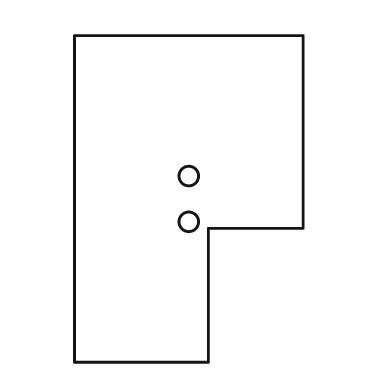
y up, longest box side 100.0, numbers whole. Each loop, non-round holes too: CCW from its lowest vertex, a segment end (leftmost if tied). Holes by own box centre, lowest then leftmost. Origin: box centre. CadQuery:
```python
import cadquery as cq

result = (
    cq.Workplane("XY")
    .moveTo(-35.0, -50.0)
    .lineTo(6.0, -50.0)
    .lineTo(6.0, -9.0)
    .lineTo(35.0, -9.0)
    .lineTo(35.0, 50.0)
    .lineTo(-35.0, 50.0)
    .close()
    .moveTo(0.0, -7.0)
    .circle(3.0)
    .moveTo(0.0, 7.0)
    .circle(3.0)
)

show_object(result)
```